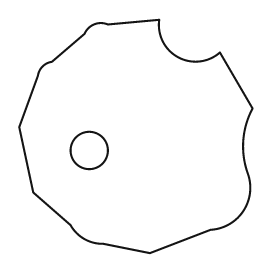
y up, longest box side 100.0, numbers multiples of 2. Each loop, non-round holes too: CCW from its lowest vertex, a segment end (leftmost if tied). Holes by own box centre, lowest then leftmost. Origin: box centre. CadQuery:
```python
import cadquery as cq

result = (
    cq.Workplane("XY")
    .moveTo(6.0, -50.0)
    .lineTo(32.0, -40.0)
    .threePointArc((46.0, -32.0), (48.0, -16.0))
    .threePointArc((46.0, -2.0), (50.0, 12.0))
    .lineTo(36.0, 36.0)
    .threePointArc((18.0, 34.0), (10.0, 50.0))
    .lineTo(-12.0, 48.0)
    .threePointArc((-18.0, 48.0), (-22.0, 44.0))
    .lineTo(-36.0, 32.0)
    .threePointArc((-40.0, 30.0), (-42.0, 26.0))
    .lineTo(-50.0, 4.0)
    .lineTo(-44.0, -24.0)
    .lineTo(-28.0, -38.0)
    .threePointArc((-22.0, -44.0), (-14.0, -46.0))
    .close()
    .moveTo(-20.0, -6.0)
    .circle(8.0)
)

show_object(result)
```